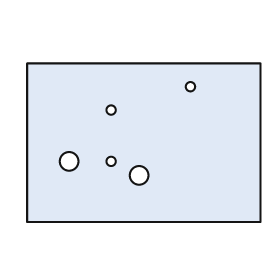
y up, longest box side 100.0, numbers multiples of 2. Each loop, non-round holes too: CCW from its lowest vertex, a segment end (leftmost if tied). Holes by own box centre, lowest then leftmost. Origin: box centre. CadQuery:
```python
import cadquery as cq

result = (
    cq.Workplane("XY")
    .moveTo(-50.0, -34.0)
    .lineTo(50.0, -34.0)
    .lineTo(50.0, 34.0)
    .lineTo(-50.0, 34.0)
    .close()
    .moveTo(-2.0, -14.0)
    .circle(4.0)
    .moveTo(-32.0, -8.0)
    .circle(4.0)
    .moveTo(-14.0, -8.0)
    .circle(2.0)
    .moveTo(-14.0, 14.0)
    .circle(2.0)
    .moveTo(20.0, 24.0)
    .circle(2.0)
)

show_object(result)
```